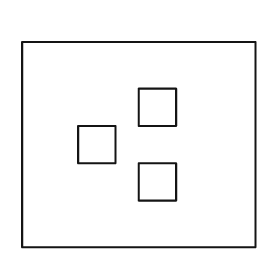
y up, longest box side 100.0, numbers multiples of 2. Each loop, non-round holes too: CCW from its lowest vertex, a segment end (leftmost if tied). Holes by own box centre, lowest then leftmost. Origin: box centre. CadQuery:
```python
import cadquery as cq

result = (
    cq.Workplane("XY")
    .moveTo(-50.0, -44.0)
    .lineTo(50.0, -44.0)
    .lineTo(50.0, 44.0)
    .lineTo(-50.0, 44.0)
    .close()
    .moveTo(0.0, -24.0)
    .lineTo(16.0, -24.0)
    .lineTo(16.0, -8.0)
    .lineTo(0.0, -8.0)
    .close()
    .moveTo(-26.0, -8.0)
    .lineTo(-10.0, -8.0)
    .lineTo(-10.0, 8.0)
    .lineTo(-26.0, 8.0)
    .close()
    .moveTo(0.0, 8.0)
    .lineTo(16.0, 8.0)
    .lineTo(16.0, 24.0)
    .lineTo(0.0, 24.0)
    .close()
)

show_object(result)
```